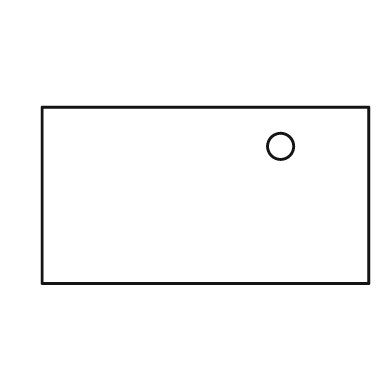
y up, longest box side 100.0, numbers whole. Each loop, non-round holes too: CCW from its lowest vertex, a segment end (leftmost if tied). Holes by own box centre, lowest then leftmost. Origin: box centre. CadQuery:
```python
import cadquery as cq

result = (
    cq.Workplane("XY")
    .moveTo(-50.0, -27.0)
    .lineTo(50.0, -27.0)
    .lineTo(50.0, 27.0)
    .lineTo(-50.0, 27.0)
    .close()
    .moveTo(23.0, 15.0)
    .circle(4.0)
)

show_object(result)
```